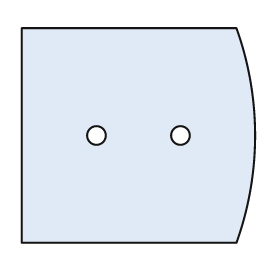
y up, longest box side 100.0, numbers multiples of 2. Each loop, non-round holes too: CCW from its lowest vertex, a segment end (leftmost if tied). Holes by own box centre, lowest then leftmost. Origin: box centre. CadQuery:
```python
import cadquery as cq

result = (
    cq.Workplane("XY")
    .moveTo(-50.0, -46.0)
    .lineTo(42.0, -46.0)
    .threePointArc((50.0, 0.0), (42.0, 46.0))
    .lineTo(-50.0, 46.0)
    .close()
    .moveTo(-18.0, 0.0)
    .circle(4.0)
    .moveTo(18.0, 0.0)
    .circle(4.0)
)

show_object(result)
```